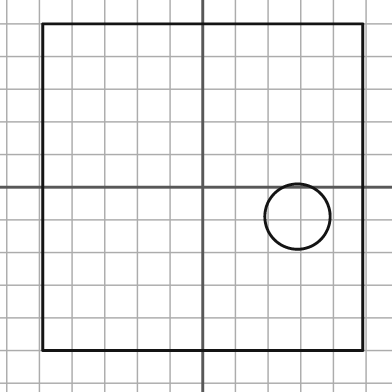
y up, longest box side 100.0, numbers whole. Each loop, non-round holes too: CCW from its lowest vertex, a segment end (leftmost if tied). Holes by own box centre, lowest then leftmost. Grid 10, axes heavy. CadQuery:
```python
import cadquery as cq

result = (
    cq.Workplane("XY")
    .moveTo(-49.0, -50.0)
    .lineTo(49.0, -50.0)
    .lineTo(49.0, 50.0)
    .lineTo(-49.0, 50.0)
    .close()
    .moveTo(29.0, -9.0)
    .circle(10.0)
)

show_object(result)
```